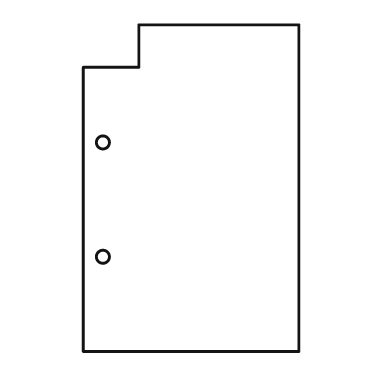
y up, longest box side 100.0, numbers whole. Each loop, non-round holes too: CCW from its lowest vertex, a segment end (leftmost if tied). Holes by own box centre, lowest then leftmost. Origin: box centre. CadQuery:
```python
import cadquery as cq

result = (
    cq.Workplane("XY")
    .moveTo(-33.0, -50.0)
    .lineTo(33.0, -50.0)
    .lineTo(33.0, 50.0)
    .lineTo(-16.0, 50.0)
    .lineTo(-16.0, 37.0)
    .lineTo(-33.0, 37.0)
    .close()
    .moveTo(-27.0, -21.0)
    .circle(2.0)
    .moveTo(-27.0, 14.0)
    .circle(2.0)
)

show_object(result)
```